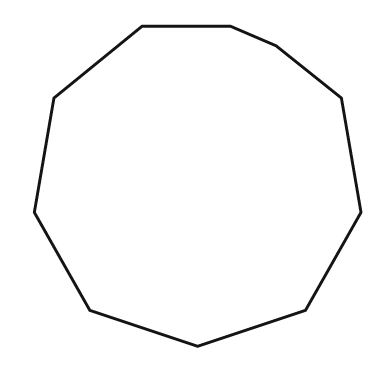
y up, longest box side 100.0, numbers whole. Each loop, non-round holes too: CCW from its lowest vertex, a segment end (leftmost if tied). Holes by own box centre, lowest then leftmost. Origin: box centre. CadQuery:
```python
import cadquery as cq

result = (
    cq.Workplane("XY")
    .moveTo(0.0, -49.0)
    .lineTo(33.0, -38.0)
    .lineTo(50.0, -8.0)
    .lineTo(44.0, 27.0)
    .lineTo(24.0, 43.0)
    .lineTo(10.0, 49.0)
    .lineTo(-17.0, 49.0)
    .lineTo(-44.0, 27.0)
    .lineTo(-50.0, -8.0)
    .lineTo(-33.0, -38.0)
    .close()
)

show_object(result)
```